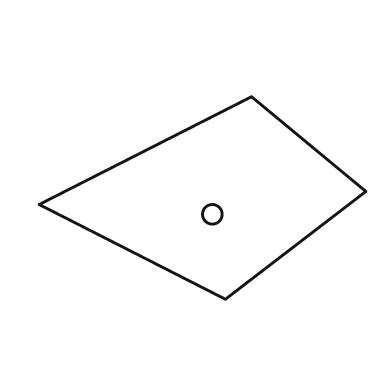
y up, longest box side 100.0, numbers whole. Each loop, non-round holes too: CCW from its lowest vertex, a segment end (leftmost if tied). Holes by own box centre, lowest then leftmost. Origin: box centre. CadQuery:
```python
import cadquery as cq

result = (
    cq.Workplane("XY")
    .moveTo(7.0, -31.0)
    .lineTo(50.0, 2.0)
    .lineTo(15.0, 31.0)
    .lineTo(-50.0, -2.0)
    .close()
    .moveTo(3.0, -5.0)
    .circle(3.0)
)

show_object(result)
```